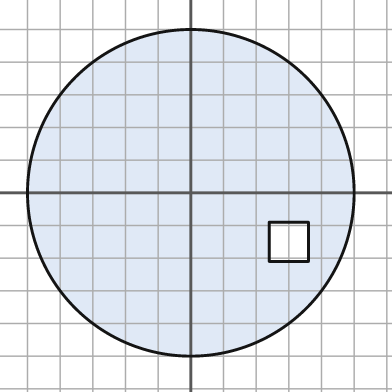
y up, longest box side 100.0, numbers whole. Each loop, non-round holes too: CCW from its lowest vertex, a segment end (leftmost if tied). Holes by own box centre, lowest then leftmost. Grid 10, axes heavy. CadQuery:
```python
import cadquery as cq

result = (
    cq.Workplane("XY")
    .moveTo(0.0, 0.0)
    .circle(50.0)
    .moveTo(24.0, -21.0)
    .lineTo(36.0, -21.0)
    .lineTo(36.0, -9.0)
    .lineTo(24.0, -9.0)
    .close()
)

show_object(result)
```